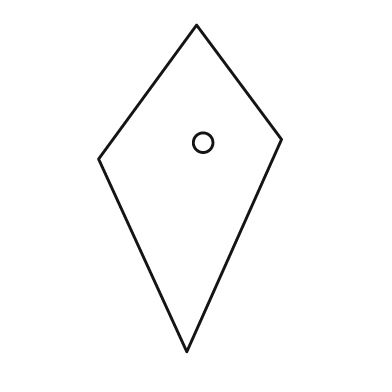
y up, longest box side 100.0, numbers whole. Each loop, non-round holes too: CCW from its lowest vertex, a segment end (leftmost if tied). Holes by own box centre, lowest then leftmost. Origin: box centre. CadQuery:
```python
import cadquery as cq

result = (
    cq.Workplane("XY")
    .moveTo(-1.0, -50.0)
    .lineTo(28.0, 15.0)
    .lineTo(2.0, 50.0)
    .lineTo(-28.0, 9.0)
    .close()
    .moveTo(4.0, 14.0)
    .circle(3.0)
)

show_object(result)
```